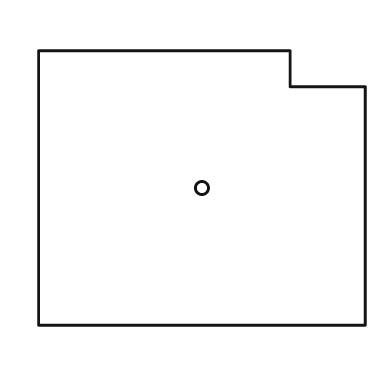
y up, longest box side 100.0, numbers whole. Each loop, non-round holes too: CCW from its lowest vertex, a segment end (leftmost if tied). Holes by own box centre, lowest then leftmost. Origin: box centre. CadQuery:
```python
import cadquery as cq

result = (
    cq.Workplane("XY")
    .moveTo(-50.0, -42.0)
    .lineTo(50.0, -42.0)
    .lineTo(50.0, 31.0)
    .lineTo(27.0, 31.0)
    .lineTo(27.0, 42.0)
    .lineTo(-50.0, 42.0)
    .close()
    .moveTo(0.0, 0.0)
    .circle(2.0)
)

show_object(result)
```